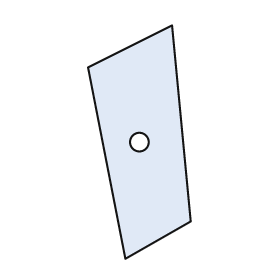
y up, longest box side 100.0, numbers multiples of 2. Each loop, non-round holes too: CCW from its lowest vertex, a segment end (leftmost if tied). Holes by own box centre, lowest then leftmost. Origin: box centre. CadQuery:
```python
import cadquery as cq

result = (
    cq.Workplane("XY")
    .moveTo(-6.0, -50.0)
    .lineTo(22.0, -34.0)
    .lineTo(14.0, 50.0)
    .lineTo(-22.0, 32.0)
    .close()
    .moveTo(0.0, 0.0)
    .circle(4.0)
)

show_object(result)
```